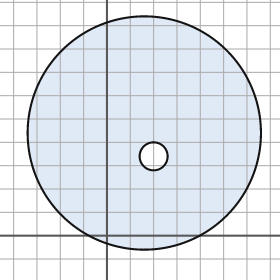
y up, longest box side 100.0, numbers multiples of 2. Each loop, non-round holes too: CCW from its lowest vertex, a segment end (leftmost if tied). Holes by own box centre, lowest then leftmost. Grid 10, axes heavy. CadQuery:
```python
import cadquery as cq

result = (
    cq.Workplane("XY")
    .moveTo(16.0, 44.0)
    .circle(50.0)
    .moveTo(20.0, 34.0)
    .circle(6.0)
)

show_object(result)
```